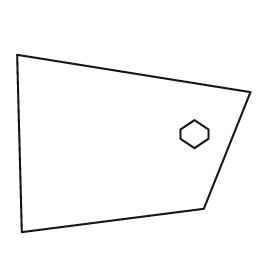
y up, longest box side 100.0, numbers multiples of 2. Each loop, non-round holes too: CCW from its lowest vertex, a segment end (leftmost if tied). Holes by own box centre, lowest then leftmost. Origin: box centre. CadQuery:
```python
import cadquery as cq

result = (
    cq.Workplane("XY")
    .moveTo(-48.0, -38.0)
    .lineTo(30.0, -28.0)
    .lineTo(50.0, 22.0)
    .lineTo(-50.0, 38.0)
    .close()
    .moveTo(26.0, -2.0)
    .lineTo(32.0, 2.0)
    .lineTo(32.0, 6.0)
    .lineTo(26.0, 10.0)
    .lineTo(20.0, 6.0)
    .lineTo(20.0, 2.0)
    .close()
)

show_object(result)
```